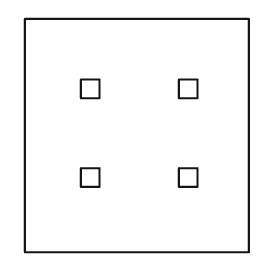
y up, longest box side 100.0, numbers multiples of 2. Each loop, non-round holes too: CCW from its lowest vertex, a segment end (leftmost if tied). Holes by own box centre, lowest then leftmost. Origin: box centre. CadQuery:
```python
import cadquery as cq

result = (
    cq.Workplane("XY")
    .moveTo(-48.0, -50.0)
    .lineTo(48.0, -50.0)
    .lineTo(48.0, 50.0)
    .lineTo(-48.0, 50.0)
    .close()
    .moveTo(-24.0, -22.0)
    .lineTo(-16.0, -22.0)
    .lineTo(-16.0, -14.0)
    .lineTo(-24.0, -14.0)
    .close()
    .moveTo(18.0, -22.0)
    .lineTo(26.0, -22.0)
    .lineTo(26.0, -14.0)
    .lineTo(18.0, -14.0)
    .close()
    .moveTo(-24.0, 16.0)
    .lineTo(-16.0, 16.0)
    .lineTo(-16.0, 24.0)
    .lineTo(-24.0, 24.0)
    .close()
    .moveTo(18.0, 16.0)
    .lineTo(26.0, 16.0)
    .lineTo(26.0, 24.0)
    .lineTo(18.0, 24.0)
    .close()
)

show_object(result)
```